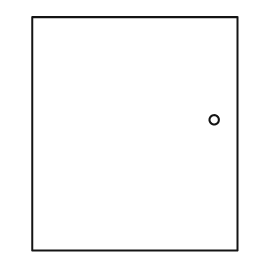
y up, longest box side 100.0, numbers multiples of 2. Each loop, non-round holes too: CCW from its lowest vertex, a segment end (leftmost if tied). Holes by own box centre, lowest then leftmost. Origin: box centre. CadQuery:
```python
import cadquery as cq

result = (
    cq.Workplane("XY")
    .moveTo(-44.0, -50.0)
    .lineTo(44.0, -50.0)
    .lineTo(44.0, 50.0)
    .lineTo(-44.0, 50.0)
    .close()
    .moveTo(34.0, 6.0)
    .circle(2.0)
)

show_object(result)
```